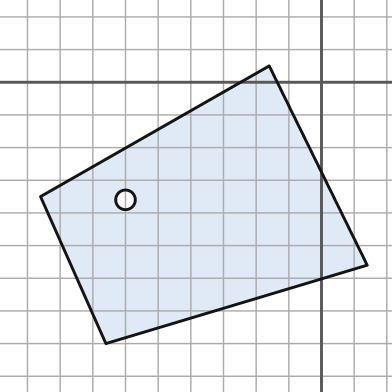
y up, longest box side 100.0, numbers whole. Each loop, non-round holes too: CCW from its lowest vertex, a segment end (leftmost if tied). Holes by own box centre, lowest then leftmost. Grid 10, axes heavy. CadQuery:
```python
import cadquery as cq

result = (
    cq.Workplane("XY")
    .moveTo(-66.0, -80.0)
    .lineTo(14.0, -56.0)
    .lineTo(-16.0, 5.0)
    .lineTo(-86.0, -35.0)
    .close()
    .moveTo(-60.0, -36.0)
    .circle(3.0)
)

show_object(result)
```